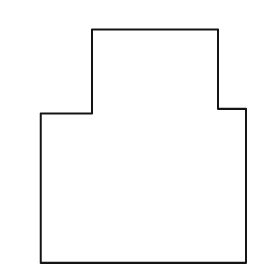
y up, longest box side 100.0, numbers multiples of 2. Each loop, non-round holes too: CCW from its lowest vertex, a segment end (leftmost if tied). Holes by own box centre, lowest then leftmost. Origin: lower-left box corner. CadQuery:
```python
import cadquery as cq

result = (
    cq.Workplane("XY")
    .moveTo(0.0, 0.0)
    .lineTo(88.0, 0.0)
    .lineTo(88.0, 66.0)
    .lineTo(76.0, 66.0)
    .lineTo(76.0, 100.0)
    .lineTo(22.0, 100.0)
    .lineTo(22.0, 64.0)
    .lineTo(0.0, 64.0)
    .close()
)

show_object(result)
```